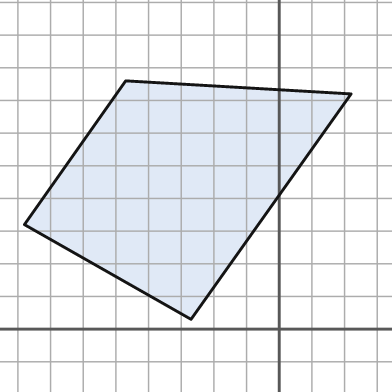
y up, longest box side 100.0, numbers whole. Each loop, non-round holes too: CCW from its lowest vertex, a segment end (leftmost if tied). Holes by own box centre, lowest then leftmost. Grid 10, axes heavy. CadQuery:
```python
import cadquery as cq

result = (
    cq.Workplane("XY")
    .moveTo(-27.0, 3.0)
    .lineTo(22.0, 72.0)
    .lineTo(-47.0, 76.0)
    .lineTo(-78.0, 32.0)
    .close()
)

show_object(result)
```